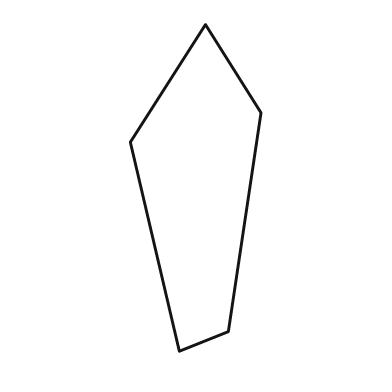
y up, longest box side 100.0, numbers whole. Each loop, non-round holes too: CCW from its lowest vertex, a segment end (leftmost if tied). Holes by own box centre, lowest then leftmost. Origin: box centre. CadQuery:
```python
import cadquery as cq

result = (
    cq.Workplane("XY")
    .moveTo(-5.0, -50.0)
    .lineTo(10.0, -44.0)
    .lineTo(20.0, 23.0)
    .lineTo(3.0, 50.0)
    .lineTo(-20.0, 14.0)
    .close()
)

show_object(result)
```